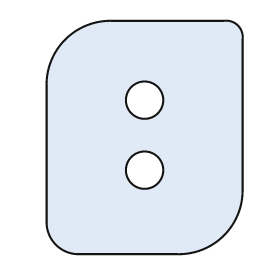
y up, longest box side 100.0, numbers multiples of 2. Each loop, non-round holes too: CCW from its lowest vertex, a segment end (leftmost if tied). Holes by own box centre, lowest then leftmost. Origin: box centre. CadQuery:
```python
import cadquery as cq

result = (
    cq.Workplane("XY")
    .moveTo(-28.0, -50.0)
    .lineTo(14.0, -50.0)
    .threePointArc((34.0, -42.0), (42.0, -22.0))
    .lineTo(42.0, 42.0)
    .threePointArc((40.0, 48.0), (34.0, 50.0))
    .lineTo(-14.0, 50.0)
    .threePointArc((-34.0, 42.0), (-42.0, 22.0))
    .lineTo(-42.0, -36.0)
    .threePointArc((-38.0, -46.0), (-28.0, -50.0))
    .close()
    .moveTo(0.0, -14.0)
    .circle(8.0)
    .moveTo(0.0, 16.0)
    .circle(8.0)
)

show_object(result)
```